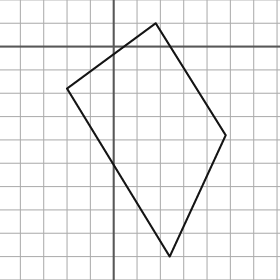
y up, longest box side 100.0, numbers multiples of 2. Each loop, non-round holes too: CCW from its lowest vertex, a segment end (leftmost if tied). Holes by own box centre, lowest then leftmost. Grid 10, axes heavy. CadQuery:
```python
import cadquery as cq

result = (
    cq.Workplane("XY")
    .moveTo(24.0, -90.0)
    .lineTo(48.0, -38.0)
    .lineTo(18.0, 10.0)
    .lineTo(-20.0, -18.0)
    .close()
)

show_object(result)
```